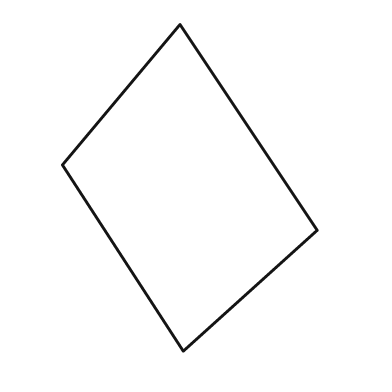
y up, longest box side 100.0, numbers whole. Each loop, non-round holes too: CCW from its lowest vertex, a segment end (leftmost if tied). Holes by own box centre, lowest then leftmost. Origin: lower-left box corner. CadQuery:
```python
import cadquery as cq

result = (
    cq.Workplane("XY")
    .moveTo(37.0, 0.0)
    .lineTo(78.0, 37.0)
    .lineTo(36.0, 100.0)
    .lineTo(0.0, 57.0)
    .close()
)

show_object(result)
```